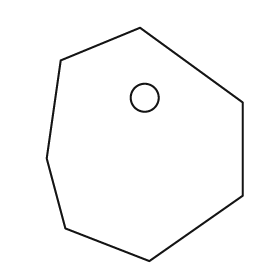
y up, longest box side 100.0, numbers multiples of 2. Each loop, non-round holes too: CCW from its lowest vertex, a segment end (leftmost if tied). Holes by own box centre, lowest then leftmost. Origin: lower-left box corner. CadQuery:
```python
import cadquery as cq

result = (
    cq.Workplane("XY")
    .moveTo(44.0, 0.0)
    .lineTo(84.0, 28.0)
    .lineTo(84.0, 68.0)
    .lineTo(40.0, 100.0)
    .lineTo(6.0, 86.0)
    .lineTo(0.0, 44.0)
    .lineTo(8.0, 14.0)
    .close()
    .moveTo(42.0, 70.0)
    .circle(6.0)
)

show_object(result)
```